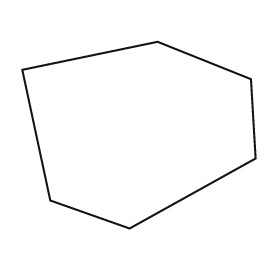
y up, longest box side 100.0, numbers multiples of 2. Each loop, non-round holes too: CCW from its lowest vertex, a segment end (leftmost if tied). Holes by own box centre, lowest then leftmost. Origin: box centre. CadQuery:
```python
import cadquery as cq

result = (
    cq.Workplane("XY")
    .moveTo(-4.0, -40.0)
    .lineTo(50.0, -10.0)
    .lineTo(48.0, 24.0)
    .lineTo(8.0, 40.0)
    .lineTo(-50.0, 28.0)
    .lineTo(-38.0, -28.0)
    .close()
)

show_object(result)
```